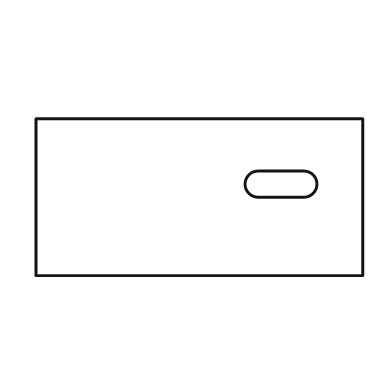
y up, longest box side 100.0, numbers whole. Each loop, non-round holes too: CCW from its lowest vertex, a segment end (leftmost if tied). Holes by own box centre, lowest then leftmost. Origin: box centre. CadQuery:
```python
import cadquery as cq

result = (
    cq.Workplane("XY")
    .moveTo(-50.0, -24.0)
    .lineTo(50.0, -24.0)
    .lineTo(50.0, 24.0)
    .lineTo(-50.0, 24.0)
    .close()
    .moveTo(18.0, 0.0)
    .lineTo(32.0, 0.0)
    .threePointArc((36.0, 4.0), (32.0, 8.0))
    .lineTo(18.0, 8.0)
    .threePointArc((14.0, 4.0), (18.0, 0.0))
    .close()
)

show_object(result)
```